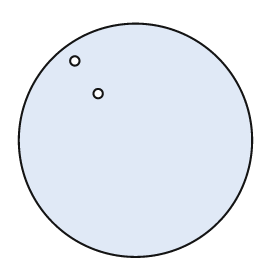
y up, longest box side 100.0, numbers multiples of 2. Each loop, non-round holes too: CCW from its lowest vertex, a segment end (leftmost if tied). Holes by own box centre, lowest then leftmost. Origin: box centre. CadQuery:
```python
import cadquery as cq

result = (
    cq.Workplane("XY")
    .moveTo(0.0, 0.0)
    .circle(50.0)
    .moveTo(-16.0, 20.0)
    .circle(2.0)
    .moveTo(-26.0, 34.0)
    .circle(2.0)
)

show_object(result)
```